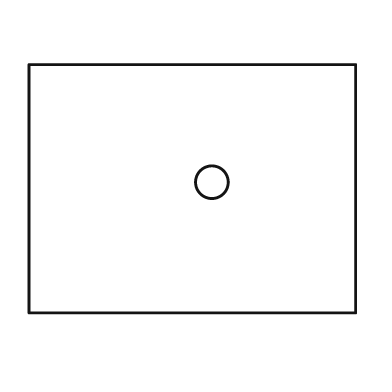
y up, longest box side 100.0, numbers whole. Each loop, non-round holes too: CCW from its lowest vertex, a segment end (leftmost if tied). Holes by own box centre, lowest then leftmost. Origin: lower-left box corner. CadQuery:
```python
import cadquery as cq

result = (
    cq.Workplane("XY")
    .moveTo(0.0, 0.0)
    .lineTo(100.0, 0.0)
    .lineTo(100.0, 76.0)
    .lineTo(0.0, 76.0)
    .close()
    .moveTo(56.0, 40.0)
    .circle(5.0)
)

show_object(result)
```